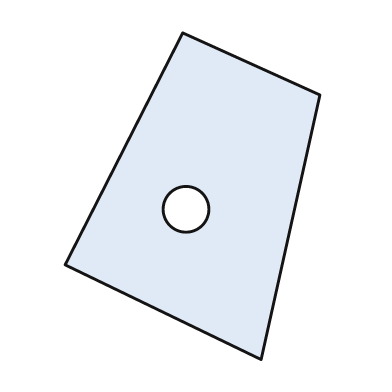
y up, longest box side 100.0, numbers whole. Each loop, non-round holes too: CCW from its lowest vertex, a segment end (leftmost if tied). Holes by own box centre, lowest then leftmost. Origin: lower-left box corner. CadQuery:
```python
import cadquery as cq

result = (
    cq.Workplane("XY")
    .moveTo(60.0, 0.0)
    .lineTo(78.0, 81.0)
    .lineTo(36.0, 100.0)
    .lineTo(0.0, 29.0)
    .close()
    .moveTo(37.0, 46.0)
    .circle(7.0)
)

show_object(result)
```